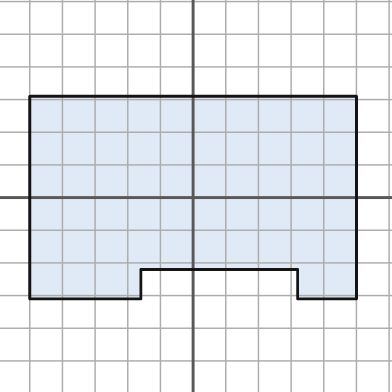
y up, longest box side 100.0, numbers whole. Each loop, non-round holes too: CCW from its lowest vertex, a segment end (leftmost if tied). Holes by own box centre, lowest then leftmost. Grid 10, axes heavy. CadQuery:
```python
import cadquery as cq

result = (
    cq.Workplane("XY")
    .moveTo(-50.0, -31.0)
    .lineTo(-16.0, -31.0)
    .lineTo(-16.0, -22.0)
    .lineTo(32.0, -22.0)
    .lineTo(32.0, -31.0)
    .lineTo(50.0, -31.0)
    .lineTo(50.0, 31.0)
    .lineTo(-50.0, 31.0)
    .close()
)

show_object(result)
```